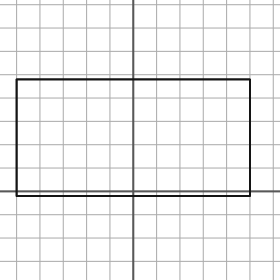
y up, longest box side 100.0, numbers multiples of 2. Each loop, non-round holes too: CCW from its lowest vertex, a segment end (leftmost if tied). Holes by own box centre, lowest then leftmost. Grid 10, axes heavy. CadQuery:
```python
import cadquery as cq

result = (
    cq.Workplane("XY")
    .moveTo(-50.0, -2.0)
    .lineTo(50.0, -2.0)
    .lineTo(50.0, 48.0)
    .lineTo(-50.0, 48.0)
    .close()
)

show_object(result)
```